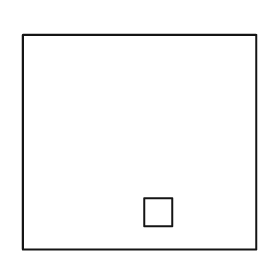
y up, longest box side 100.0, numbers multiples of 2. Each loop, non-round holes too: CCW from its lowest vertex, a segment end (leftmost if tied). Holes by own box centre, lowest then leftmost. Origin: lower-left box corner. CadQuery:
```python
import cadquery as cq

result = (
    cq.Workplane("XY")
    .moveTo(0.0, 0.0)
    .lineTo(100.0, 0.0)
    .lineTo(100.0, 92.0)
    .lineTo(0.0, 92.0)
    .close()
    .moveTo(52.0, 10.0)
    .lineTo(64.0, 10.0)
    .lineTo(64.0, 22.0)
    .lineTo(52.0, 22.0)
    .close()
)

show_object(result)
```